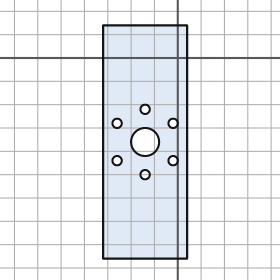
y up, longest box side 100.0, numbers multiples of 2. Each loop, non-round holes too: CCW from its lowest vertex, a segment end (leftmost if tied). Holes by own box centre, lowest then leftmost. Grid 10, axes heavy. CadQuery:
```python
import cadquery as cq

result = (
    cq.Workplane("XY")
    .moveTo(-32.0, -86.0)
    .lineTo(4.0, -86.0)
    .lineTo(4.0, 14.0)
    .lineTo(-32.0, 14.0)
    .close()
    .moveTo(-14.0, -50.0)
    .circle(2.0)
    .moveTo(-26.0, -44.0)
    .circle(2.0)
    .moveTo(-2.0, -44.0)
    .circle(2.0)
    .moveTo(-14.0, -36.0)
    .circle(6.0)
    .moveTo(-26.0, -28.0)
    .circle(2.0)
    .moveTo(-2.0, -28.0)
    .circle(2.0)
    .moveTo(-14.0, -22.0)
    .circle(2.0)
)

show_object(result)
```